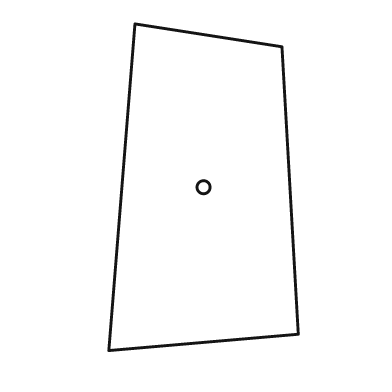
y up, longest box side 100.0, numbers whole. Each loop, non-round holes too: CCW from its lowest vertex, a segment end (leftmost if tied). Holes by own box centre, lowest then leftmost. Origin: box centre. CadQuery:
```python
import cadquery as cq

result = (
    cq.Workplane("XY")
    .moveTo(-29.0, -50.0)
    .lineTo(29.0, -45.0)
    .lineTo(24.0, 43.0)
    .lineTo(-21.0, 50.0)
    .close()
    .moveTo(0.0, 0.0)
    .circle(2.0)
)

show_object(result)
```